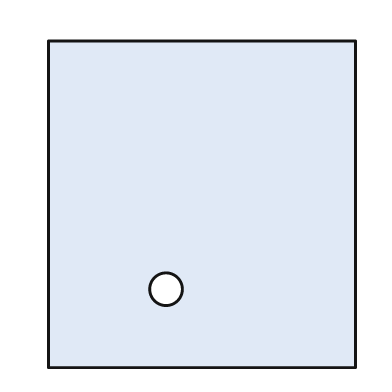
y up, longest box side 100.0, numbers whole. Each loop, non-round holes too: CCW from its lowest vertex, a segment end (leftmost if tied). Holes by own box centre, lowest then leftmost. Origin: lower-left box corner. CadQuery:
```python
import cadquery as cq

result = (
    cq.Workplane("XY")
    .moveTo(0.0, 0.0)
    .lineTo(94.0, 0.0)
    .lineTo(94.0, 100.0)
    .lineTo(0.0, 100.0)
    .close()
    .moveTo(36.0, 24.0)
    .circle(5.0)
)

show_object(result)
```